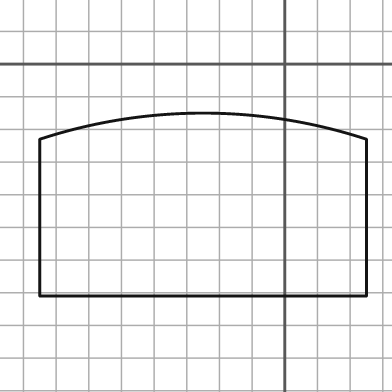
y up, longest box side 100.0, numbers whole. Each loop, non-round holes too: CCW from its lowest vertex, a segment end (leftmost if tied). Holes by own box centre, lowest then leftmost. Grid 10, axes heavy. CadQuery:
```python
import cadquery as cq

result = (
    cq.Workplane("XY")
    .moveTo(-75.0, -71.0)
    .lineTo(25.0, -71.0)
    .lineTo(25.0, -23.0)
    .threePointArc((-25.0, -15.0), (-75.0, -23.0))
    .close()
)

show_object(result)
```